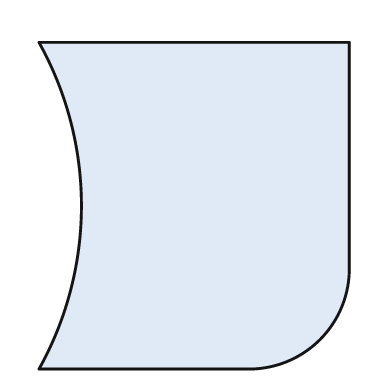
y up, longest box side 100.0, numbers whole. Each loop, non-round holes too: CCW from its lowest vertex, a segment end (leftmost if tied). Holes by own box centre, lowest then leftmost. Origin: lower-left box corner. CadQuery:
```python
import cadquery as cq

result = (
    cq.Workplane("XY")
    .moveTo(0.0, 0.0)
    .lineTo(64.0, 0.0)
    .threePointArc((86.0, 9.0), (95.0, 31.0))
    .lineTo(95.0, 100.0)
    .lineTo(0.0, 100.0)
    .threePointArc((13.0, 50.0), (0.0, 0.0))
    .close()
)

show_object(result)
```